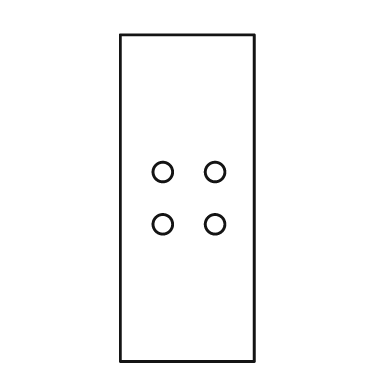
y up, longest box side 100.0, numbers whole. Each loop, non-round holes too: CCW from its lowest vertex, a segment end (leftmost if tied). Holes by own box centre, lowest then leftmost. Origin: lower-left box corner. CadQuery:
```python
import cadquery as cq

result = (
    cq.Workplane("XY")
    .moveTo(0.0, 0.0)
    .lineTo(41.0, 0.0)
    .lineTo(41.0, 100.0)
    .lineTo(0.0, 100.0)
    .close()
    .moveTo(13.0, 42.0)
    .circle(3.0)
    .moveTo(29.0, 42.0)
    .circle(3.0)
    .moveTo(13.0, 58.0)
    .circle(3.0)
    .moveTo(29.0, 58.0)
    .circle(3.0)
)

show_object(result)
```